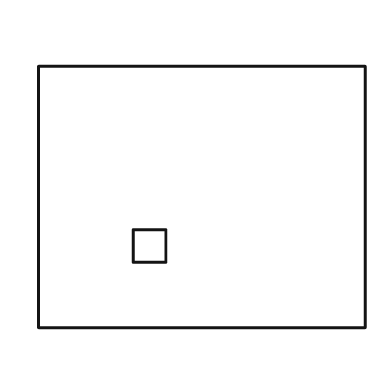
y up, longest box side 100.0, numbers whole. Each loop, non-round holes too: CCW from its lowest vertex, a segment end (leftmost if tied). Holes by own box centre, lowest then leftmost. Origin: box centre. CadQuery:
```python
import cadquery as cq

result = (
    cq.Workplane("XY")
    .moveTo(-50.0, -40.0)
    .lineTo(50.0, -40.0)
    .lineTo(50.0, 40.0)
    .lineTo(-50.0, 40.0)
    .close()
    .moveTo(-21.0, -20.0)
    .lineTo(-11.0, -20.0)
    .lineTo(-11.0, -10.0)
    .lineTo(-21.0, -10.0)
    .close()
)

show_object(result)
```